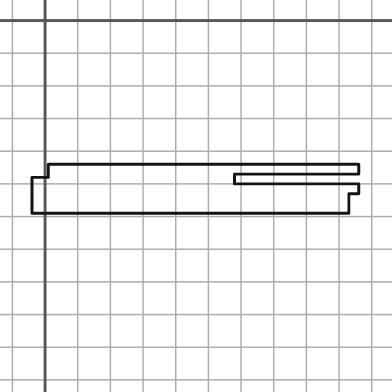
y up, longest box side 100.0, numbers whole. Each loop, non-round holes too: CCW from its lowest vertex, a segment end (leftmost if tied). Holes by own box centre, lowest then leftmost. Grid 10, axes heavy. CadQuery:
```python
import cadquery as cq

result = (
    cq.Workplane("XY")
    .moveTo(-4.0, -59.0)
    .lineTo(93.0, -59.0)
    .lineTo(93.0, -53.0)
    .lineTo(96.0, -53.0)
    .lineTo(96.0, -50.0)
    .lineTo(58.0, -50.0)
    .lineTo(58.0, -47.0)
    .lineTo(96.0, -47.0)
    .lineTo(96.0, -44.0)
    .lineTo(1.0, -44.0)
    .lineTo(1.0, -48.0)
    .lineTo(-4.0, -48.0)
    .close()
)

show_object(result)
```